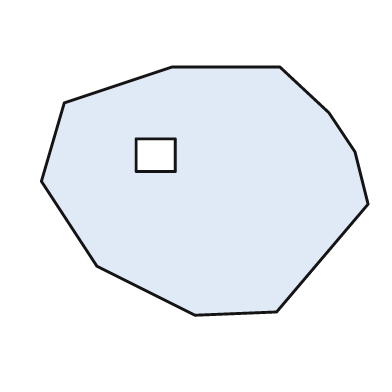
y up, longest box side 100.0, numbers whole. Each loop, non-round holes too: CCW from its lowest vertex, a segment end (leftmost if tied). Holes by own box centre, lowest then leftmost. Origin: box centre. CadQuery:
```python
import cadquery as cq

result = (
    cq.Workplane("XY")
    .moveTo(-3.0, -38.0)
    .lineTo(22.0, -37.0)
    .lineTo(50.0, -4.0)
    .lineTo(46.0, 12.0)
    .lineTo(38.0, 24.0)
    .lineTo(23.0, 38.0)
    .lineTo(-10.0, 38.0)
    .lineTo(-43.0, 27.0)
    .lineTo(-50.0, 3.0)
    .lineTo(-33.0, -23.0)
    .close()
    .moveTo(-21.0, 6.0)
    .lineTo(-9.0, 6.0)
    .lineTo(-9.0, 16.0)
    .lineTo(-21.0, 16.0)
    .close()
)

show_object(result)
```